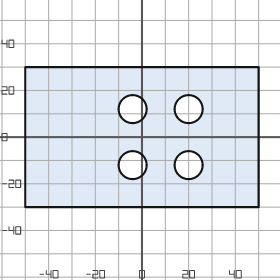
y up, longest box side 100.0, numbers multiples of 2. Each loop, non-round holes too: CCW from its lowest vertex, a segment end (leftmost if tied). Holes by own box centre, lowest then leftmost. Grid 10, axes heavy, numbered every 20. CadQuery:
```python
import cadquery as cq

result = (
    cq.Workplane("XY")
    .moveTo(-50.0, -30.0)
    .lineTo(50.0, -30.0)
    .lineTo(50.0, 30.0)
    .lineTo(-50.0, 30.0)
    .close()
    .moveTo(-4.0, -12.0)
    .circle(6.0)
    .moveTo(20.0, -12.0)
    .circle(6.0)
    .moveTo(-4.0, 12.0)
    .circle(6.0)
    .moveTo(20.0, 12.0)
    .circle(6.0)
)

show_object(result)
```